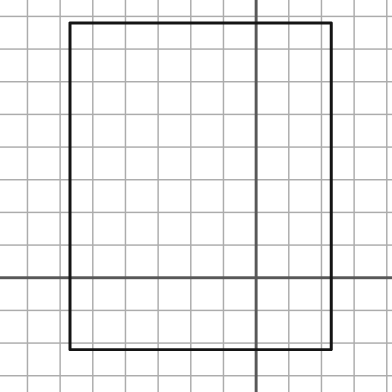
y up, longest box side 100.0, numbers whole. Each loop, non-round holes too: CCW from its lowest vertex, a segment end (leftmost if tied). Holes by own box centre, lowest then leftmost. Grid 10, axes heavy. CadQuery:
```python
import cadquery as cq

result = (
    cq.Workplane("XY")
    .moveTo(-57.0, -22.0)
    .lineTo(23.0, -22.0)
    .lineTo(23.0, 78.0)
    .lineTo(-57.0, 78.0)
    .close()
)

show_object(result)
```